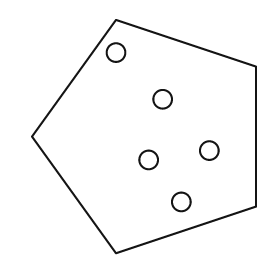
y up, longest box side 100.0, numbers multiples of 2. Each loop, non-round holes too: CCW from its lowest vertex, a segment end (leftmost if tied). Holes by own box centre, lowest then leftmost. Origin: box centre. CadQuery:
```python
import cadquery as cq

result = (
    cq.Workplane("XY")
    .moveTo(-12.0, -50.0)
    .lineTo(48.0, -30.0)
    .lineTo(48.0, 30.0)
    .lineTo(-12.0, 50.0)
    .lineTo(-48.0, 0.0)
    .close()
    .moveTo(16.0, -28.0)
    .circle(4.0)
    .moveTo(2.0, -10.0)
    .circle(4.0)
    .moveTo(28.0, -6.0)
    .circle(4.0)
    .moveTo(8.0, 16.0)
    .circle(4.0)
    .moveTo(-12.0, 36.0)
    .circle(4.0)
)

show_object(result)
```